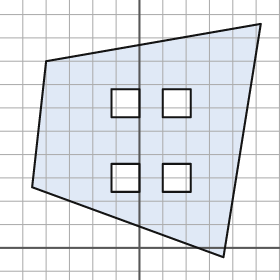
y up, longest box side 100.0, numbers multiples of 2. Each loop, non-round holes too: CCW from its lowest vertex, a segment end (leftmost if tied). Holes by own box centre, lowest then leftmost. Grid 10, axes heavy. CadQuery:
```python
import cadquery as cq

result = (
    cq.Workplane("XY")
    .moveTo(36.0, -4.0)
    .lineTo(52.0, 96.0)
    .lineTo(-40.0, 80.0)
    .lineTo(-46.0, 26.0)
    .close()
    .moveTo(-12.0, 24.0)
    .lineTo(0.0, 24.0)
    .lineTo(0.0, 36.0)
    .lineTo(-12.0, 36.0)
    .close()
    .moveTo(10.0, 24.0)
    .lineTo(22.0, 24.0)
    .lineTo(22.0, 36.0)
    .lineTo(10.0, 36.0)
    .close()
    .moveTo(-12.0, 56.0)
    .lineTo(0.0, 56.0)
    .lineTo(0.0, 68.0)
    .lineTo(-12.0, 68.0)
    .close()
    .moveTo(10.0, 56.0)
    .lineTo(22.0, 56.0)
    .lineTo(22.0, 68.0)
    .lineTo(10.0, 68.0)
    .close()
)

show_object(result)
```